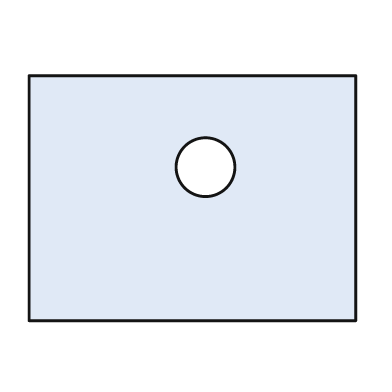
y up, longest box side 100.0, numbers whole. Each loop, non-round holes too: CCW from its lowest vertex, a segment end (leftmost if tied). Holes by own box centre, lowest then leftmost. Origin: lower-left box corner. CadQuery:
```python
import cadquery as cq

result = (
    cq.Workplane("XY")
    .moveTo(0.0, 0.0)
    .lineTo(100.0, 0.0)
    .lineTo(100.0, 75.0)
    .lineTo(0.0, 75.0)
    .close()
    .moveTo(54.0, 47.0)
    .circle(9.0)
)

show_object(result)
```